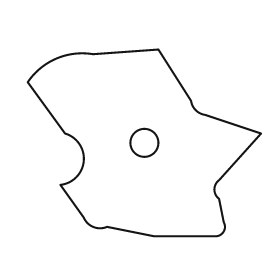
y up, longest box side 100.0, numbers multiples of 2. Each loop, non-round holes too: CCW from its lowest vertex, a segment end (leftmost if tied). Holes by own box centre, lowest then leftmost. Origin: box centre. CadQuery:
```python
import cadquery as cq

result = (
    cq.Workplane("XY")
    .moveTo(4.0, -40.0)
    .lineTo(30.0, -40.0)
    .threePointArc((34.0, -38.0), (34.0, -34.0))
    .lineTo(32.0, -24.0)
    .threePointArc((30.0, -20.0), (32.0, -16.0))
    .lineTo(50.0, 4.0)
    .lineTo(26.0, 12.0)
    .threePointArc((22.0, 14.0), (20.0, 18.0))
    .lineTo(6.0, 40.0)
    .lineTo(-22.0, 38.0)
    .threePointArc((-38.0, 36.0), (-50.0, 26.0))
    .lineTo(-34.0, 4.0)
    .threePointArc((-26.0, -8.0), (-36.0, -18.0))
    .lineTo(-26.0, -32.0)
    .threePointArc((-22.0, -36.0), (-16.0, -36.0))
    .close()
    .moveTo(0.0, 0.0)
    .circle(6.0)
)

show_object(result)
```